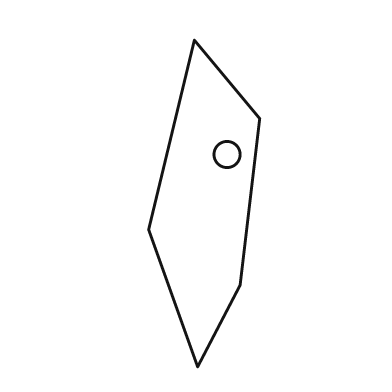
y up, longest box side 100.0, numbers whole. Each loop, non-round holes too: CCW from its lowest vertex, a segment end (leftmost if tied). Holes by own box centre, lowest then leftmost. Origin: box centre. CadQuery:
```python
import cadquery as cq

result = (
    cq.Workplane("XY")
    .moveTo(-2.0, -50.0)
    .lineTo(11.0, -25.0)
    .lineTo(17.0, 26.0)
    .lineTo(-3.0, 50.0)
    .lineTo(-17.0, -8.0)
    .close()
    .moveTo(7.0, 15.0)
    .circle(4.0)
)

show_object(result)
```